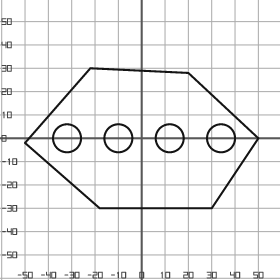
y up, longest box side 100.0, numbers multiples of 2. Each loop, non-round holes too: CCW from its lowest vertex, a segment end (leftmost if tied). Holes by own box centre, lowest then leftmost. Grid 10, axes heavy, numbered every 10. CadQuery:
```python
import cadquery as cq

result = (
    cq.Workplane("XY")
    .moveTo(-18.0, -30.0)
    .lineTo(30.0, -30.0)
    .lineTo(50.0, 0.0)
    .lineTo(20.0, 28.0)
    .lineTo(-22.0, 30.0)
    .lineTo(-50.0, -2.0)
    .close()
    .moveTo(-32.0, 0.0)
    .circle(6.0)
    .moveTo(-10.0, 0.0)
    .circle(6.0)
    .moveTo(12.0, 0.0)
    .circle(6.0)
    .moveTo(34.0, 0.0)
    .circle(6.0)
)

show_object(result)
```